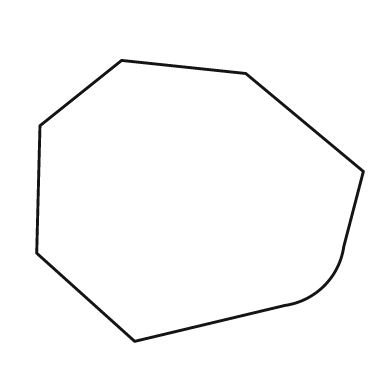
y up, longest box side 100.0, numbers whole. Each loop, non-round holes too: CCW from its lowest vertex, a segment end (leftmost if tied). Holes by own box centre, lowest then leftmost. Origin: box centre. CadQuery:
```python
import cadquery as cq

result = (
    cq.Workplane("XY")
    .moveTo(-20.0, -43.0)
    .lineTo(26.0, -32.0)
    .threePointArc((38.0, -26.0), (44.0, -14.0))
    .lineTo(50.0, 9.0)
    .lineTo(14.0, 39.0)
    .lineTo(-24.0, 43.0)
    .lineTo(-49.0, 23.0)
    .lineTo(-50.0, -16.0)
    .close()
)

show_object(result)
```